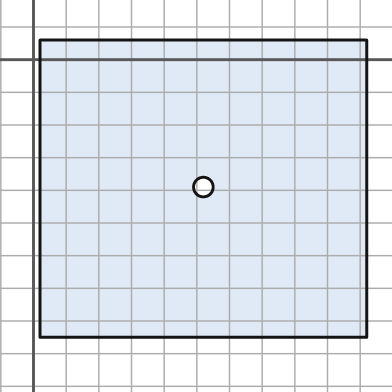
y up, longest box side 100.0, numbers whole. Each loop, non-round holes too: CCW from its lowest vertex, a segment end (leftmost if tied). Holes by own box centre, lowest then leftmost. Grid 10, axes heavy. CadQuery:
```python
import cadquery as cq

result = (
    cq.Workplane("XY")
    .moveTo(2.0, -85.0)
    .lineTo(102.0, -85.0)
    .lineTo(102.0, 6.0)
    .lineTo(2.0, 6.0)
    .close()
    .moveTo(52.0, -39.0)
    .circle(3.0)
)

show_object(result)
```